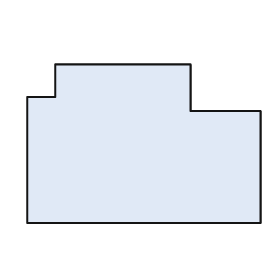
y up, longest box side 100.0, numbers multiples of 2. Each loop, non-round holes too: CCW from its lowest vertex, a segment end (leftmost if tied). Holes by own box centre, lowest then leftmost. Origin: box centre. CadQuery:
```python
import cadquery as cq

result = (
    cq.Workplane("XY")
    .moveTo(-50.0, -34.0)
    .lineTo(50.0, -34.0)
    .lineTo(50.0, 14.0)
    .lineTo(20.0, 14.0)
    .lineTo(20.0, 34.0)
    .lineTo(-38.0, 34.0)
    .lineTo(-38.0, 20.0)
    .lineTo(-50.0, 20.0)
    .close()
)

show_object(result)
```